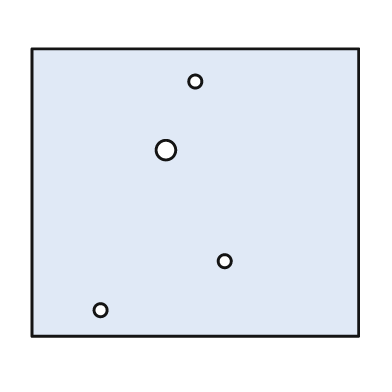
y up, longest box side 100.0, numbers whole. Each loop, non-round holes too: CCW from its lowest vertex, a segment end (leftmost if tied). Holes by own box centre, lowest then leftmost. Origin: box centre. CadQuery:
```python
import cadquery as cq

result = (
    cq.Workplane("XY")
    .moveTo(-50.0, -44.0)
    .lineTo(50.0, -44.0)
    .lineTo(50.0, 44.0)
    .lineTo(-50.0, 44.0)
    .close()
    .moveTo(-29.0, -36.0)
    .circle(2.0)
    .moveTo(9.0, -21.0)
    .circle(2.0)
    .moveTo(-9.0, 13.0)
    .circle(3.0)
    .moveTo(0.0, 34.0)
    .circle(2.0)
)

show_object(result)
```